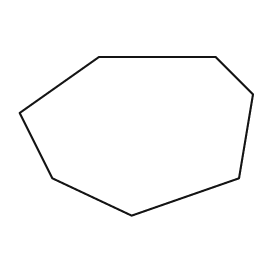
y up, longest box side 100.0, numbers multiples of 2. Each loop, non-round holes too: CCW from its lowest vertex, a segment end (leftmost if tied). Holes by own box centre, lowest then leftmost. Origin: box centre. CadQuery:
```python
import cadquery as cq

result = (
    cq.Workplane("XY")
    .moveTo(-2.0, -34.0)
    .lineTo(44.0, -18.0)
    .lineTo(50.0, 18.0)
    .lineTo(34.0, 34.0)
    .lineTo(-16.0, 34.0)
    .lineTo(-50.0, 10.0)
    .lineTo(-36.0, -18.0)
    .close()
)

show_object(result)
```